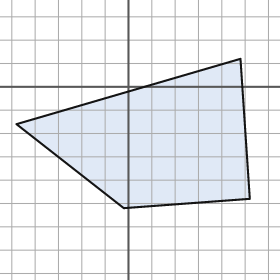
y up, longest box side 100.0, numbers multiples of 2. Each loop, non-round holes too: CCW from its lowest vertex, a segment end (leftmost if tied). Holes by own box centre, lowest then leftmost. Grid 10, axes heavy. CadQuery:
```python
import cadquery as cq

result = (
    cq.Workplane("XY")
    .moveTo(-2.0, -52.0)
    .lineTo(52.0, -48.0)
    .lineTo(48.0, 12.0)
    .lineTo(-48.0, -16.0)
    .close()
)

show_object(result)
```